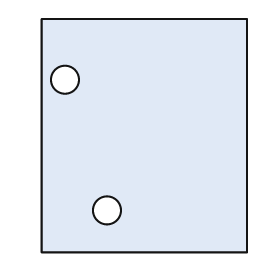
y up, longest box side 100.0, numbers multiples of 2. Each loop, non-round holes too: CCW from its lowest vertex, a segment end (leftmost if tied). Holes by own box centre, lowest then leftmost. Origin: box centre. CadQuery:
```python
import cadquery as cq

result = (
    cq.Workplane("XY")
    .moveTo(-44.0, -50.0)
    .lineTo(44.0, -50.0)
    .lineTo(44.0, 50.0)
    .lineTo(-44.0, 50.0)
    .close()
    .moveTo(-16.0, -32.0)
    .circle(6.0)
    .moveTo(-34.0, 24.0)
    .circle(6.0)
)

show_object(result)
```